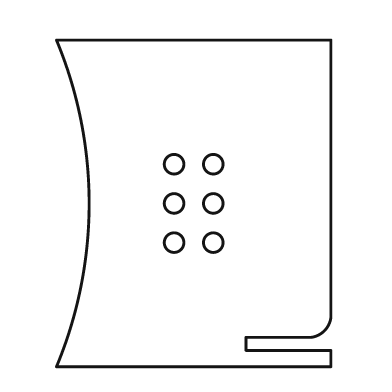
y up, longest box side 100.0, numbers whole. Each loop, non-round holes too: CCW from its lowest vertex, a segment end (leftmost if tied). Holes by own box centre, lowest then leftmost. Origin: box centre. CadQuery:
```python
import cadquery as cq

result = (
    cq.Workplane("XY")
    .moveTo(-42.0, -50.0)
    .lineTo(42.0, -50.0)
    .lineTo(42.0, -45.0)
    .lineTo(16.0, -45.0)
    .lineTo(16.0, -41.0)
    .lineTo(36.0, -41.0)
    .threePointArc((40.0, -39.0), (42.0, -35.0))
    .lineTo(42.0, 50.0)
    .lineTo(-42.0, 50.0)
    .threePointArc((-32.0, 0.0), (-42.0, -50.0))
    .close()
    .moveTo(-6.0, -12.0)
    .circle(3.0)
    .moveTo(6.0, -12.0)
    .circle(3.0)
    .moveTo(-6.0, 0.0)
    .circle(3.0)
    .moveTo(6.0, 0.0)
    .circle(3.0)
    .moveTo(-6.0, 12.0)
    .circle(3.0)
    .moveTo(6.0, 12.0)
    .circle(3.0)
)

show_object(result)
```